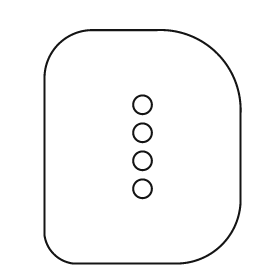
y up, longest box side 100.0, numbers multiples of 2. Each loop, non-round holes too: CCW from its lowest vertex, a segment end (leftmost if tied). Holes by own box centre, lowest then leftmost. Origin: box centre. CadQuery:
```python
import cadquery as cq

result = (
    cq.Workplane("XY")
    .moveTo(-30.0, -50.0)
    .lineTo(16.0, -50.0)
    .threePointArc((34.0, -42.0), (42.0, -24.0))
    .lineTo(42.0, 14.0)
    .threePointArc((32.0, 40.0), (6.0, 50.0))
    .lineTo(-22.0, 50.0)
    .threePointArc((-36.0, 44.0), (-42.0, 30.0))
    .lineTo(-42.0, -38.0)
    .threePointArc((-38.0, -46.0), (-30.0, -50.0))
    .close()
    .moveTo(0.0, -18.0)
    .circle(4.0)
    .moveTo(0.0, -6.0)
    .circle(4.0)
    .moveTo(0.0, 6.0)
    .circle(4.0)
    .moveTo(0.0, 18.0)
    .circle(4.0)
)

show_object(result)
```